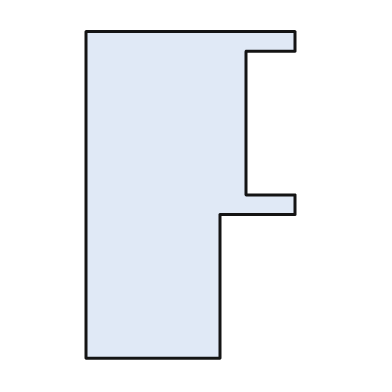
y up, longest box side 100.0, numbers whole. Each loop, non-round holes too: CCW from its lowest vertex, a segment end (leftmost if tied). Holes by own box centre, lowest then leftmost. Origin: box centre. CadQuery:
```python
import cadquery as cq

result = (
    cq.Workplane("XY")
    .moveTo(-32.0, -50.0)
    .lineTo(9.0, -50.0)
    .lineTo(9.0, -6.0)
    .lineTo(32.0, -6.0)
    .lineTo(32.0, 0.0)
    .lineTo(17.0, 0.0)
    .lineTo(17.0, 44.0)
    .lineTo(32.0, 44.0)
    .lineTo(32.0, 50.0)
    .lineTo(-32.0, 50.0)
    .close()
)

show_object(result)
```